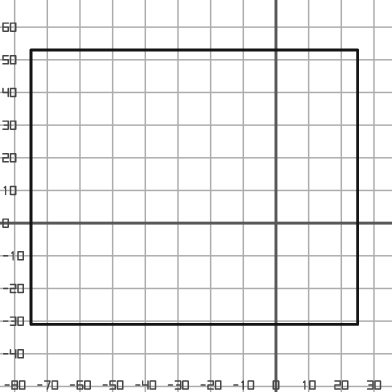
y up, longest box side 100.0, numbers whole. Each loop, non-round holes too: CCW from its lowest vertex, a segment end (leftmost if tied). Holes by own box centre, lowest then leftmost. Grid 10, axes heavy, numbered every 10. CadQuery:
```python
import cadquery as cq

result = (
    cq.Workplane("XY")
    .moveTo(-75.0, -31.0)
    .lineTo(25.0, -31.0)
    .lineTo(25.0, 53.0)
    .lineTo(-75.0, 53.0)
    .close()
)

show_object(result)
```